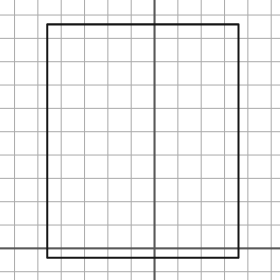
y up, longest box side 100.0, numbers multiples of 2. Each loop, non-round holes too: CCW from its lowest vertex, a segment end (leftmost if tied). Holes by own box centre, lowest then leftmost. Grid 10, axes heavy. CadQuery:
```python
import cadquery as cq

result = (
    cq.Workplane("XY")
    .moveTo(-46.0, -4.0)
    .lineTo(36.0, -4.0)
    .lineTo(36.0, 96.0)
    .lineTo(-46.0, 96.0)
    .close()
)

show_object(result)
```